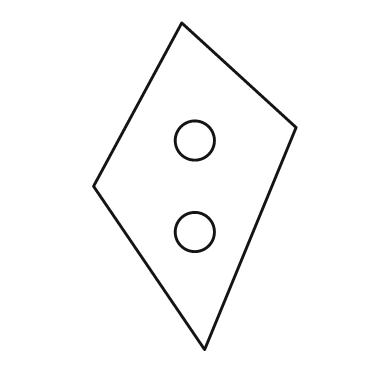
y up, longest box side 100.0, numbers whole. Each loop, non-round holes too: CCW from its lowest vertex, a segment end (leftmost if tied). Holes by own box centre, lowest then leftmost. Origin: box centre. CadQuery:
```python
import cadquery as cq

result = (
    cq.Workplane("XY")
    .moveTo(3.0, -50.0)
    .lineTo(31.0, 18.0)
    .lineTo(-4.0, 50.0)
    .lineTo(-31.0, 0.0)
    .close()
    .moveTo(0.0, -14.0)
    .circle(6.0)
    .moveTo(0.0, 14.0)
    .circle(6.0)
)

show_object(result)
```